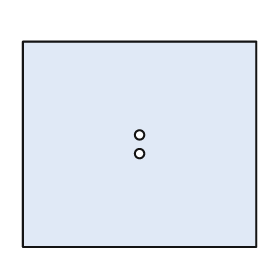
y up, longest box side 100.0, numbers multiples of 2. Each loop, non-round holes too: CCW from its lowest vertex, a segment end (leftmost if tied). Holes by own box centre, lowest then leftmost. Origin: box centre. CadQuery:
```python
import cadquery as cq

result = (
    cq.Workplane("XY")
    .moveTo(-50.0, -44.0)
    .lineTo(50.0, -44.0)
    .lineTo(50.0, 44.0)
    .lineTo(-50.0, 44.0)
    .close()
    .moveTo(0.0, -4.0)
    .circle(2.0)
    .moveTo(0.0, 4.0)
    .circle(2.0)
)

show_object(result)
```